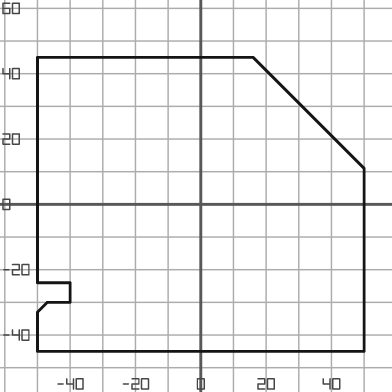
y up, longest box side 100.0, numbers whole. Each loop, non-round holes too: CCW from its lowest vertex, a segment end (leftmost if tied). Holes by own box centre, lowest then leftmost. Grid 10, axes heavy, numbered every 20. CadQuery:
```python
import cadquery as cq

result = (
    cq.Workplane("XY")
    .moveTo(-50.0, -45.0)
    .lineTo(50.0, -45.0)
    .lineTo(50.0, 11.0)
    .lineTo(16.0, 45.0)
    .lineTo(-50.0, 45.0)
    .lineTo(-50.0, -24.0)
    .lineTo(-40.0, -24.0)
    .lineTo(-40.0, -30.0)
    .lineTo(-47.0, -30.0)
    .lineTo(-50.0, -33.0)
    .close()
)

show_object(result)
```